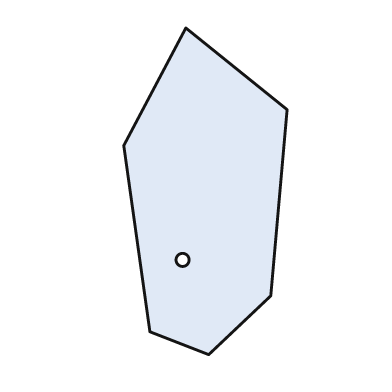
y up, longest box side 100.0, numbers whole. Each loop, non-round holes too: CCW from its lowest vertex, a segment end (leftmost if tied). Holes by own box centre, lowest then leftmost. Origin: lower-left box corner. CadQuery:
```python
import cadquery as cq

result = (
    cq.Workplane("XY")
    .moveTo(26.0, 0.0)
    .lineTo(45.0, 18.0)
    .lineTo(50.0, 75.0)
    .lineTo(19.0, 100.0)
    .lineTo(0.0, 64.0)
    .lineTo(8.0, 7.0)
    .close()
    .moveTo(18.0, 29.0)
    .circle(2.0)
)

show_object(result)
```